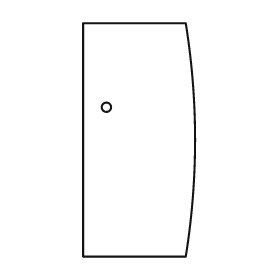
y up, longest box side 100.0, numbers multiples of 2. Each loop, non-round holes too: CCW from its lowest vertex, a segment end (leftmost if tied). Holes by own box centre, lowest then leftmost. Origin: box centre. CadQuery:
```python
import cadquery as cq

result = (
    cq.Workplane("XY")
    .moveTo(-24.0, -50.0)
    .lineTo(20.0, -50.0)
    .threePointArc((24.0, 0.0), (20.0, 50.0))
    .lineTo(-24.0, 50.0)
    .close()
    .moveTo(-14.0, 14.0)
    .circle(2.0)
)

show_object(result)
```